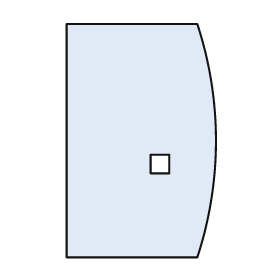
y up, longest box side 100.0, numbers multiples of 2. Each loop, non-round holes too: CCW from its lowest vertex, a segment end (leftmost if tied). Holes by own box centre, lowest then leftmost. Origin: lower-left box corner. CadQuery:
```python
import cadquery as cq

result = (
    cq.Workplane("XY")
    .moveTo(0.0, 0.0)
    .lineTo(56.0, 0.0)
    .threePointArc((64.0, 50.0), (56.0, 100.0))
    .lineTo(0.0, 100.0)
    .close()
    .moveTo(36.0, 36.0)
    .lineTo(44.0, 36.0)
    .lineTo(44.0, 44.0)
    .lineTo(36.0, 44.0)
    .close()
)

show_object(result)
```